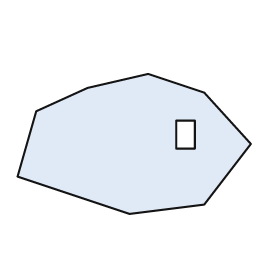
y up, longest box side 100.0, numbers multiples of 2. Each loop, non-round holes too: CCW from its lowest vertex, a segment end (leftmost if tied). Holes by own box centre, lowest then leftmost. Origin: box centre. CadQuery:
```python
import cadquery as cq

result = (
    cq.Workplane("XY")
    .moveTo(-2.0, -30.0)
    .lineTo(30.0, -26.0)
    .lineTo(50.0, 0.0)
    .lineTo(30.0, 22.0)
    .lineTo(6.0, 30.0)
    .lineTo(-20.0, 24.0)
    .lineTo(-42.0, 14.0)
    .lineTo(-50.0, -14.0)
    .close()
    .moveTo(18.0, -2.0)
    .lineTo(26.0, -2.0)
    .lineTo(26.0, 10.0)
    .lineTo(18.0, 10.0)
    .close()
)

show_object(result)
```